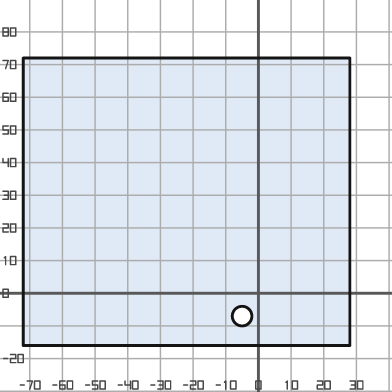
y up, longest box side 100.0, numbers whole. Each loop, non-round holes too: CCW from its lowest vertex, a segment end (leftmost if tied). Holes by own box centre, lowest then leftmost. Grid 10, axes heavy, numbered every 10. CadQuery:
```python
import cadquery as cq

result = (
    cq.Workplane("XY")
    .moveTo(-72.0, -16.0)
    .lineTo(28.0, -16.0)
    .lineTo(28.0, 72.0)
    .lineTo(-72.0, 72.0)
    .close()
    .moveTo(-5.0, -7.0)
    .circle(3.0)
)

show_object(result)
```